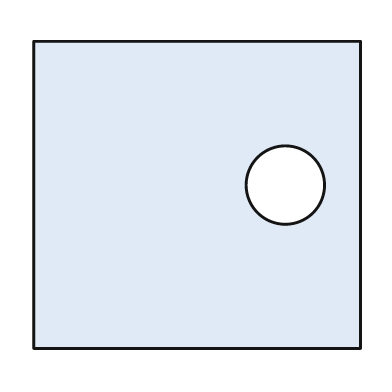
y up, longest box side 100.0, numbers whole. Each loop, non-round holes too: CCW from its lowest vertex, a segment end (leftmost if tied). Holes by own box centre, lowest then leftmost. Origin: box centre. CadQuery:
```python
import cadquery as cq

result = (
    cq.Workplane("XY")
    .moveTo(-50.0, -47.0)
    .lineTo(50.0, -47.0)
    .lineTo(50.0, 47.0)
    .lineTo(-50.0, 47.0)
    .close()
    .moveTo(27.0, 3.0)
    .circle(12.0)
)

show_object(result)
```